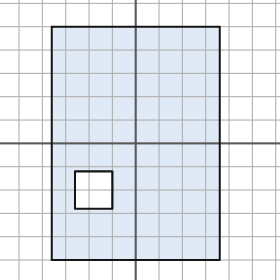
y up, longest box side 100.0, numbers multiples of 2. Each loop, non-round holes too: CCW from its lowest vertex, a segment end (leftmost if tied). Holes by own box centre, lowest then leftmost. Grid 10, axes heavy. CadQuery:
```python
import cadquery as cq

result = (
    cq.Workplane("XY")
    .moveTo(-36.0, -50.0)
    .lineTo(36.0, -50.0)
    .lineTo(36.0, 50.0)
    .lineTo(-36.0, 50.0)
    .close()
    .moveTo(-26.0, -28.0)
    .lineTo(-10.0, -28.0)
    .lineTo(-10.0, -12.0)
    .lineTo(-26.0, -12.0)
    .close()
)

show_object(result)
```